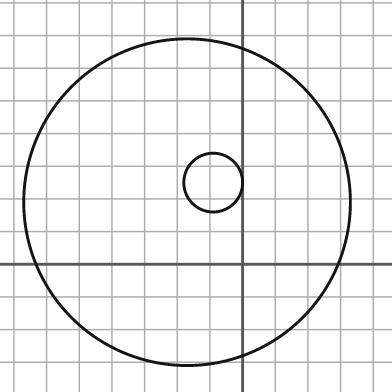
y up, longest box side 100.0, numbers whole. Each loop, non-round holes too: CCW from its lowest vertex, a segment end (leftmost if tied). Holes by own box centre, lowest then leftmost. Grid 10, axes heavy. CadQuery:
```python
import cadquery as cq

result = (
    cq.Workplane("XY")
    .moveTo(-17.0, 19.0)
    .circle(50.0)
    .moveTo(-9.0, 25.0)
    .circle(9.0)
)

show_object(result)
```